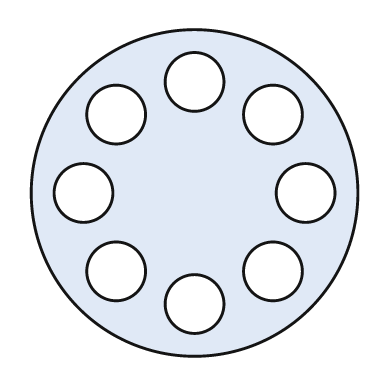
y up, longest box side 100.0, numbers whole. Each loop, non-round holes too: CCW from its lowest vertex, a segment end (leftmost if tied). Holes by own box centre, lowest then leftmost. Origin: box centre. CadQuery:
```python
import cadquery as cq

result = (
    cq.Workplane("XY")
    .moveTo(0.0, 0.0)
    .circle(50.0)
    .moveTo(0.0, -34.0)
    .circle(9.0)
    .moveTo(-24.0, -24.0)
    .circle(9.0)
    .moveTo(24.0, -24.0)
    .circle(9.0)
    .moveTo(-34.0, 0.0)
    .circle(9.0)
    .moveTo(34.0, 0.0)
    .circle(9.0)
    .moveTo(-24.0, 24.0)
    .circle(9.0)
    .moveTo(24.0, 24.0)
    .circle(9.0)
    .moveTo(0.0, 34.0)
    .circle(9.0)
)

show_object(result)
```